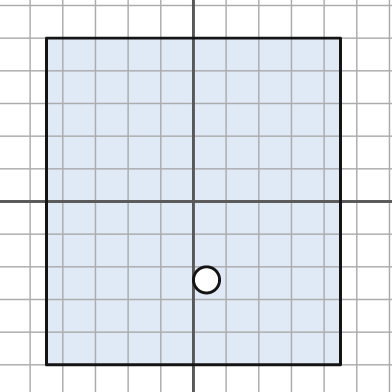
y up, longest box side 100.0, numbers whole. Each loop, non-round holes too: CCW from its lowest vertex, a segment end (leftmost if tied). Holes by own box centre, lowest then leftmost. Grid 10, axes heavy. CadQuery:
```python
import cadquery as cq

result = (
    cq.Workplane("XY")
    .moveTo(-45.0, -50.0)
    .lineTo(45.0, -50.0)
    .lineTo(45.0, 50.0)
    .lineTo(-45.0, 50.0)
    .close()
    .moveTo(4.0, -24.0)
    .circle(4.0)
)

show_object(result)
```